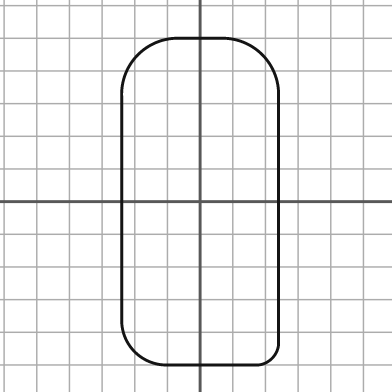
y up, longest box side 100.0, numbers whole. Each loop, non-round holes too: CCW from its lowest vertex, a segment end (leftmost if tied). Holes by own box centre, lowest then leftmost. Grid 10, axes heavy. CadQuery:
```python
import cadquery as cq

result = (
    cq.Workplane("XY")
    .moveTo(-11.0, -50.0)
    .lineTo(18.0, -50.0)
    .threePointArc((22.0, -48.0), (24.0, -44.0))
    .lineTo(24.0, 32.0)
    .threePointArc((19.0, 45.0), (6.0, 50.0))
    .lineTo(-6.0, 50.0)
    .threePointArc((-19.0, 45.0), (-24.0, 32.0))
    .lineTo(-24.0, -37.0)
    .threePointArc((-20.0, -46.0), (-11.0, -50.0))
    .close()
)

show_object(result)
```